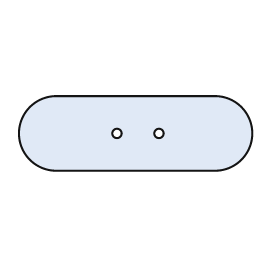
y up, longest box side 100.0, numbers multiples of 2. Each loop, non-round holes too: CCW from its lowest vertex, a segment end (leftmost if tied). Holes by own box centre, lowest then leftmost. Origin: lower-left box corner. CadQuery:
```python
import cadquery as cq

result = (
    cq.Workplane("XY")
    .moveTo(16.0, 0.0)
    .lineTo(84.0, 0.0)
    .threePointArc((100.0, 16.0), (84.0, 32.0))
    .lineTo(16.0, 32.0)
    .threePointArc((0.0, 16.0), (16.0, 0.0))
    .close()
    .moveTo(42.0, 16.0)
    .circle(2.0)
    .moveTo(60.0, 16.0)
    .circle(2.0)
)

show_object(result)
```